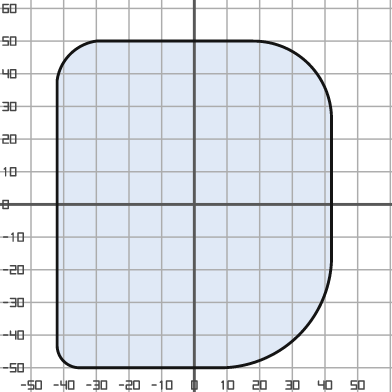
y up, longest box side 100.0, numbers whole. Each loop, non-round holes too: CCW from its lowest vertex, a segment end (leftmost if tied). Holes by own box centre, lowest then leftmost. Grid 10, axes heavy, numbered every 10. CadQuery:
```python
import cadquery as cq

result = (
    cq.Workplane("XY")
    .moveTo(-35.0, -50.0)
    .lineTo(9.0, -50.0)
    .threePointArc((32.0, -40.0), (42.0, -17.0))
    .lineTo(42.0, 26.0)
    .threePointArc((35.0, 43.0), (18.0, 50.0))
    .lineTo(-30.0, 50.0)
    .threePointArc((-38.0, 46.0), (-42.0, 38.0))
    .lineTo(-42.0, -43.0)
    .threePointArc((-40.0, -48.0), (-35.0, -50.0))
    .close()
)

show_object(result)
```